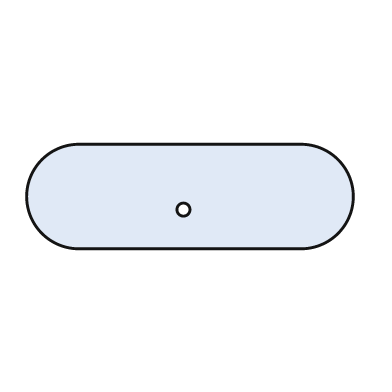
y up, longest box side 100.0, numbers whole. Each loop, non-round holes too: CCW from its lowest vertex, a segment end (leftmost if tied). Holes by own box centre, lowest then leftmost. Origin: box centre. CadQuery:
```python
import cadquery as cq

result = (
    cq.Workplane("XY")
    .moveTo(-34.0, -16.0)
    .lineTo(34.0, -16.0)
    .threePointArc((50.0, 0.0), (34.0, 16.0))
    .lineTo(-34.0, 16.0)
    .threePointArc((-50.0, 0.0), (-34.0, -16.0))
    .close()
    .moveTo(-2.0, -4.0)
    .circle(2.0)
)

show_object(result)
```